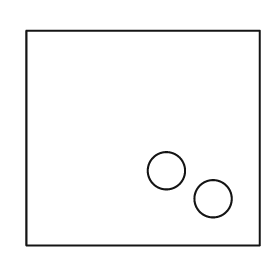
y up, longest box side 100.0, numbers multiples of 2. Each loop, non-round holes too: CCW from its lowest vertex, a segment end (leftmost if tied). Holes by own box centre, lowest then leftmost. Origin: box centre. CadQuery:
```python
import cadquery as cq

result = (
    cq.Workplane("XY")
    .moveTo(-50.0, -46.0)
    .lineTo(50.0, -46.0)
    .lineTo(50.0, 46.0)
    .lineTo(-50.0, 46.0)
    .close()
    .moveTo(30.0, -26.0)
    .circle(8.0)
    .moveTo(10.0, -14.0)
    .circle(8.0)
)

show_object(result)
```